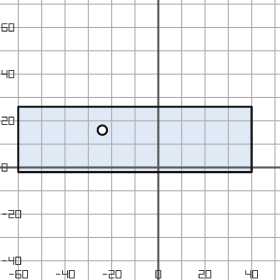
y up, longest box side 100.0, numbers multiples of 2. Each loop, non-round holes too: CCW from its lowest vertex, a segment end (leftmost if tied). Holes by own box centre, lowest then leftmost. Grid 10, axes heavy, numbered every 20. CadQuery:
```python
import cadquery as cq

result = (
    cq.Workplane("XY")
    .moveTo(-60.0, -2.0)
    .lineTo(40.0, -2.0)
    .lineTo(40.0, 26.0)
    .lineTo(-60.0, 26.0)
    .close()
    .moveTo(-24.0, 16.0)
    .circle(2.0)
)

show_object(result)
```